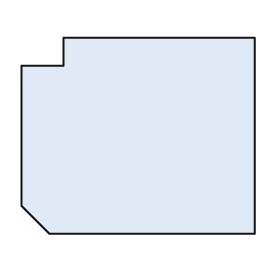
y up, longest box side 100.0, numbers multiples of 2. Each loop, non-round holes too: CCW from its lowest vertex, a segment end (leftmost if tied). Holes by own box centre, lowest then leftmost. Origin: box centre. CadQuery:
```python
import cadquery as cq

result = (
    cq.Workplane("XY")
    .moveTo(-38.0, -42.0)
    .lineTo(50.0, -42.0)
    .lineTo(50.0, 42.0)
    .lineTo(-32.0, 42.0)
    .lineTo(-32.0, 30.0)
    .lineTo(-50.0, 30.0)
    .lineTo(-50.0, -30.0)
    .close()
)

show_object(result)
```